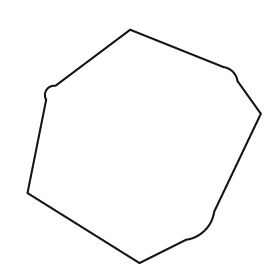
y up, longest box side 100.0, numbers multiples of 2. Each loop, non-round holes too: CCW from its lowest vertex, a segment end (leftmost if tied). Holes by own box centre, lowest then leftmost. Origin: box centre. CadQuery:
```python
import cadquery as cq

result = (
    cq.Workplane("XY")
    .moveTo(-2.0, -50.0)
    .lineTo(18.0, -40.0)
    .threePointArc((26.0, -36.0), (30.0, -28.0))
    .lineTo(50.0, 14.0)
    .lineTo(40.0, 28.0)
    .threePointArc((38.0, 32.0), (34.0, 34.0))
    .lineTo(-6.0, 50.0)
    .lineTo(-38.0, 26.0)
    .threePointArc((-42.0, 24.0), (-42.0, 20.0))
    .lineTo(-50.0, -20.0)
    .close()
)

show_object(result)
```